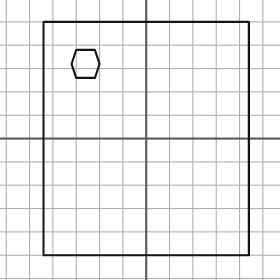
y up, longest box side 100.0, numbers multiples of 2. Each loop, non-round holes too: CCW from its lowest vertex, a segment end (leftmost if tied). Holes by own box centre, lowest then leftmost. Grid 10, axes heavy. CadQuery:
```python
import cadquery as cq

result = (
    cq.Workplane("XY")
    .moveTo(-44.0, -50.0)
    .lineTo(44.0, -50.0)
    .lineTo(44.0, 50.0)
    .lineTo(-44.0, 50.0)
    .close()
    .moveTo(-30.0, 26.0)
    .lineTo(-22.0, 26.0)
    .lineTo(-20.0, 32.0)
    .lineTo(-22.0, 38.0)
    .lineTo(-30.0, 38.0)
    .lineTo(-32.0, 32.0)
    .close()
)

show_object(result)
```